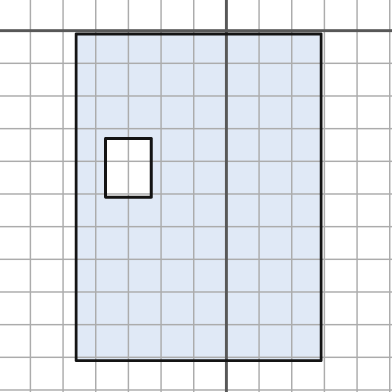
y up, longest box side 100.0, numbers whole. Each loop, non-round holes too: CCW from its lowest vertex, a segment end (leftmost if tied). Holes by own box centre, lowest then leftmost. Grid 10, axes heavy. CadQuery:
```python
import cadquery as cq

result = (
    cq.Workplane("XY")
    .moveTo(-46.0, -101.0)
    .lineTo(29.0, -101.0)
    .lineTo(29.0, -1.0)
    .lineTo(-46.0, -1.0)
    .close()
    .moveTo(-37.0, -51.0)
    .lineTo(-23.0, -51.0)
    .lineTo(-23.0, -33.0)
    .lineTo(-37.0, -33.0)
    .close()
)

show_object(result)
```